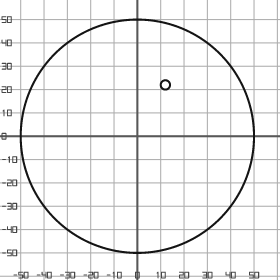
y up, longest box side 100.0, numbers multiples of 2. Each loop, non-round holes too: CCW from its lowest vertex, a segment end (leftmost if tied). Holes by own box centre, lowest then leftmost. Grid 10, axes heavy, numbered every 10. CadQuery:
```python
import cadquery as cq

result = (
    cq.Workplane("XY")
    .moveTo(0.0, 0.0)
    .circle(50.0)
    .moveTo(12.0, 22.0)
    .circle(2.0)
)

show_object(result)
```